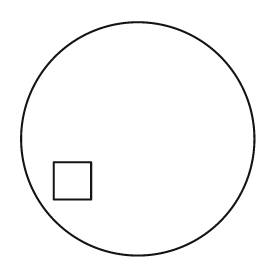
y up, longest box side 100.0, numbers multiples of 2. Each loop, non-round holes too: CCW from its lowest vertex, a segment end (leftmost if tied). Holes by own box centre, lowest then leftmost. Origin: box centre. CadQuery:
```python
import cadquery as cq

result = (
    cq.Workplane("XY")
    .moveTo(0.0, 0.0)
    .circle(50.0)
    .moveTo(-36.0, -26.0)
    .lineTo(-20.0, -26.0)
    .lineTo(-20.0, -10.0)
    .lineTo(-36.0, -10.0)
    .close()
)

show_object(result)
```